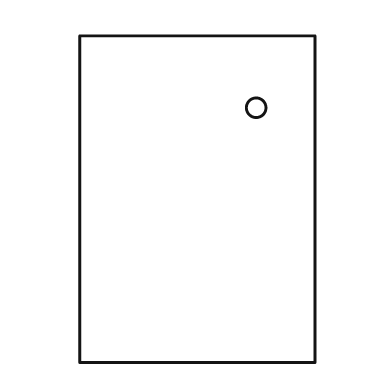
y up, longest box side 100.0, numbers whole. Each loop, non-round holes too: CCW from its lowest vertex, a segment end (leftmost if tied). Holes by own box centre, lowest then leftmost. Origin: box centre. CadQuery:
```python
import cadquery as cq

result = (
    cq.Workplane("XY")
    .moveTo(-36.0, -50.0)
    .lineTo(36.0, -50.0)
    .lineTo(36.0, 50.0)
    .lineTo(-36.0, 50.0)
    .close()
    .moveTo(18.0, 28.0)
    .circle(3.0)
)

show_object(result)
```